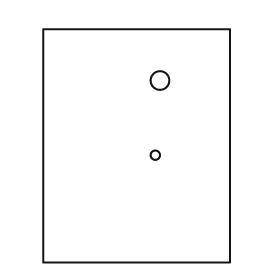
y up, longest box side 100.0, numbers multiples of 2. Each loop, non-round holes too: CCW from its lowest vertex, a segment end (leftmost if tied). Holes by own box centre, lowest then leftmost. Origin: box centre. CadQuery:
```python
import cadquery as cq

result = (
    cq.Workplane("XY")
    .moveTo(-40.0, -50.0)
    .lineTo(40.0, -50.0)
    .lineTo(40.0, 50.0)
    .lineTo(-40.0, 50.0)
    .close()
    .moveTo(8.0, -4.0)
    .circle(2.0)
    .moveTo(10.0, 28.0)
    .circle(4.0)
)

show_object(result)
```